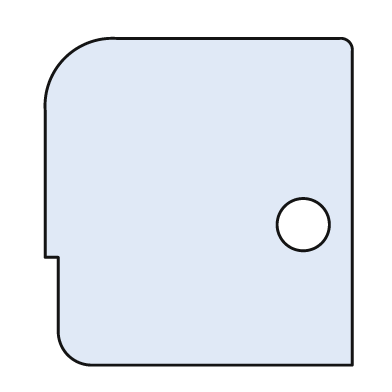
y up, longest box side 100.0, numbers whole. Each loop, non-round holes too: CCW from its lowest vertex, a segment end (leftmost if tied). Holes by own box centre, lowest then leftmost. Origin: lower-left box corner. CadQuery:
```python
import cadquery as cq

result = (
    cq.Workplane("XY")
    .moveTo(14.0, 0.0)
    .lineTo(94.0, 0.0)
    .lineTo(94.0, 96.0)
    .threePointArc((93.0, 99.0), (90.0, 100.0))
    .lineTo(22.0, 100.0)
    .threePointArc((6.0, 94.0), (0.0, 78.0))
    .lineTo(0.0, 33.0)
    .lineTo(4.0, 33.0)
    .lineTo(4.0, 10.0)
    .threePointArc((7.0, 3.0), (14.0, 0.0))
    .close()
    .moveTo(79.0, 43.0)
    .circle(8.0)
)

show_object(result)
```